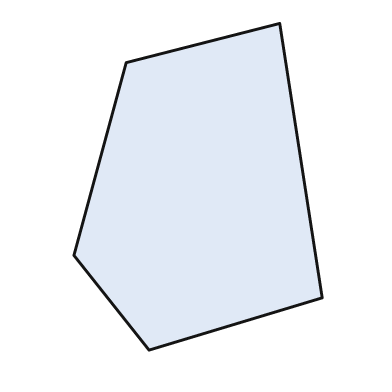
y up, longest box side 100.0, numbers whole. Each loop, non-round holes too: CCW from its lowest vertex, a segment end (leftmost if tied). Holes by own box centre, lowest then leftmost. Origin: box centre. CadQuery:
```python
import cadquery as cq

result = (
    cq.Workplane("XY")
    .moveTo(-15.0, -50.0)
    .lineTo(38.0, -34.0)
    .lineTo(25.0, 50.0)
    .lineTo(-22.0, 38.0)
    .lineTo(-38.0, -21.0)
    .close()
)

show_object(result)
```